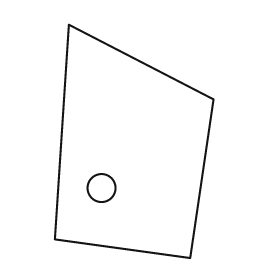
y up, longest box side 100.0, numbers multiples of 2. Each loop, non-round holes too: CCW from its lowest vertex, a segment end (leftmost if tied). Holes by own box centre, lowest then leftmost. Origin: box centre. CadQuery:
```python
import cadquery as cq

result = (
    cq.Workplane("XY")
    .moveTo(24.0, -50.0)
    .lineTo(34.0, 18.0)
    .lineTo(-28.0, 50.0)
    .lineTo(-34.0, -42.0)
    .close()
    .moveTo(-14.0, -20.0)
    .circle(6.0)
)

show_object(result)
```